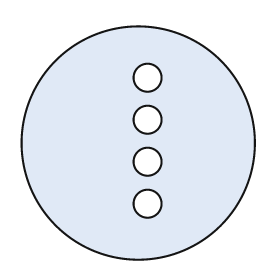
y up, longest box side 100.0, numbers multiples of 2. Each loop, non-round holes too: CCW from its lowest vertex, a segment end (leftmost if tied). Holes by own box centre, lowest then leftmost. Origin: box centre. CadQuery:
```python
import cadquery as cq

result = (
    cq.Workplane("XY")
    .moveTo(0.0, 0.0)
    .circle(50.0)
    .moveTo(4.0, -26.0)
    .circle(6.0)
    .moveTo(4.0, -8.0)
    .circle(6.0)
    .moveTo(4.0, 10.0)
    .circle(6.0)
    .moveTo(4.0, 28.0)
    .circle(6.0)
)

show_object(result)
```